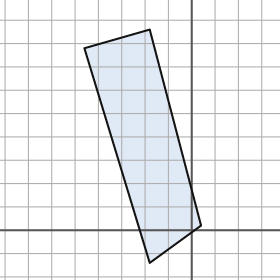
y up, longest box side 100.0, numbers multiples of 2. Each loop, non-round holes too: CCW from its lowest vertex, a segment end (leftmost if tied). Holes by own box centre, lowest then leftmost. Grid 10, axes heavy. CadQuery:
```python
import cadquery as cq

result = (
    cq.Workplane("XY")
    .moveTo(-18.0, -14.0)
    .lineTo(4.0, 2.0)
    .lineTo(-18.0, 86.0)
    .lineTo(-46.0, 78.0)
    .close()
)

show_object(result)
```